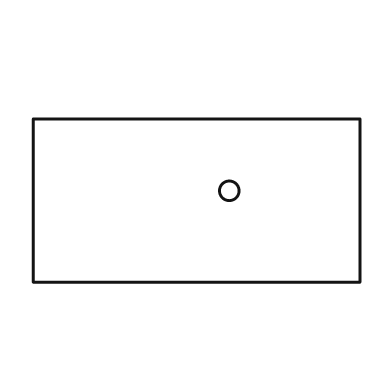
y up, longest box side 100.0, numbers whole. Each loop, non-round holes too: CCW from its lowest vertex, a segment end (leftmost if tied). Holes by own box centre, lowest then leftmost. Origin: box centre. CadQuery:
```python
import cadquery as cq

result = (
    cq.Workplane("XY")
    .moveTo(-50.0, -25.0)
    .lineTo(50.0, -25.0)
    .lineTo(50.0, 25.0)
    .lineTo(-50.0, 25.0)
    .close()
    .moveTo(10.0, 3.0)
    .circle(3.0)
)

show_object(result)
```